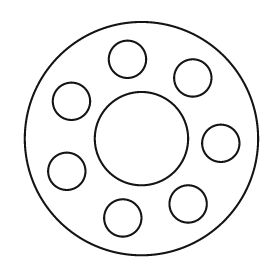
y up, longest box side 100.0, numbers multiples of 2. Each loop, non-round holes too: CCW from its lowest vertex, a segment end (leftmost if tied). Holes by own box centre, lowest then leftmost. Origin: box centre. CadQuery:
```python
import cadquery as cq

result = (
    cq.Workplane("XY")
    .moveTo(0.0, 0.0)
    .circle(50.0)
    .moveTo(-8.0, -34.0)
    .circle(8.0)
    .moveTo(20.0, -28.0)
    .circle(8.0)
    .moveTo(-32.0, -14.0)
    .circle(8.0)
    .moveTo(34.0, -2.0)
    .circle(8.0)
    .moveTo(0.0, 0.0)
    .circle(20.0)
    .moveTo(-30.0, 16.0)
    .circle(8.0)
    .moveTo(22.0, 26.0)
    .circle(8.0)
    .moveTo(-6.0, 34.0)
    .circle(8.0)
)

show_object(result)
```